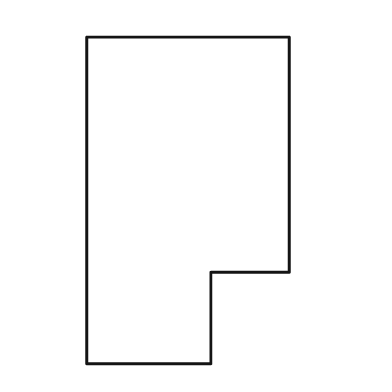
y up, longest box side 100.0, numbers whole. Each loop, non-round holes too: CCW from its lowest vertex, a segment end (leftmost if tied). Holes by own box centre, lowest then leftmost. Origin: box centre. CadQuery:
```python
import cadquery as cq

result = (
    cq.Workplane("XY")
    .moveTo(-31.0, -50.0)
    .lineTo(7.0, -50.0)
    .lineTo(7.0, -22.0)
    .lineTo(31.0, -22.0)
    .lineTo(31.0, 50.0)
    .lineTo(-31.0, 50.0)
    .close()
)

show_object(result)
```